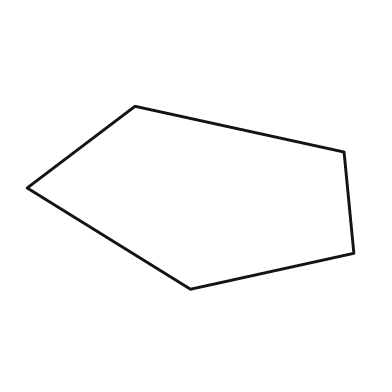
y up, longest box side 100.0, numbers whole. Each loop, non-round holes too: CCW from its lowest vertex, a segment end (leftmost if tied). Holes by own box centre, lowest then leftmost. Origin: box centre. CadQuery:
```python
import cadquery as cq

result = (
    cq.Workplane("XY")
    .moveTo(0.0, -28.0)
    .lineTo(50.0, -17.0)
    .lineTo(47.0, 14.0)
    .lineTo(-17.0, 28.0)
    .lineTo(-50.0, 3.0)
    .close()
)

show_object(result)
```